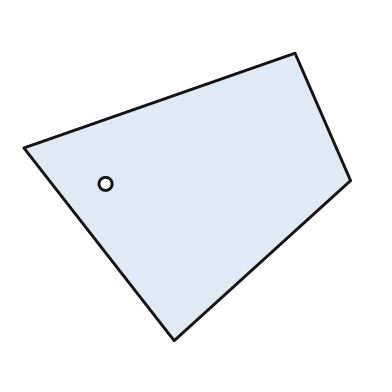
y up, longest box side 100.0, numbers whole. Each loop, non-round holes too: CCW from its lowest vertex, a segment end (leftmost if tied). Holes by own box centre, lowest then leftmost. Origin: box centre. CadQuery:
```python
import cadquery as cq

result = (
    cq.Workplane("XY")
    .moveTo(-4.0, -44.0)
    .lineTo(50.0, 5.0)
    .lineTo(33.0, 44.0)
    .lineTo(-50.0, 15.0)
    .close()
    .moveTo(-25.0, 4.0)
    .circle(2.0)
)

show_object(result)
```